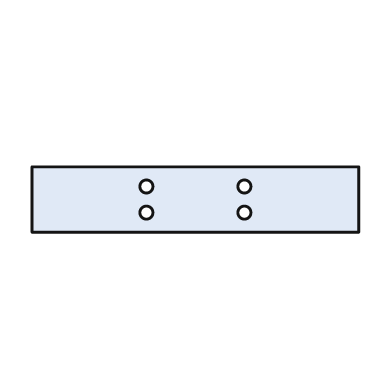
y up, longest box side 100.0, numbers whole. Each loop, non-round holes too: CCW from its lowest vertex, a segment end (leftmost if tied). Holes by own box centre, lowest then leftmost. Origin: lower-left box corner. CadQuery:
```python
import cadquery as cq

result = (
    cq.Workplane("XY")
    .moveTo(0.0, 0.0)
    .lineTo(100.0, 0.0)
    .lineTo(100.0, 20.0)
    .lineTo(0.0, 20.0)
    .close()
    .moveTo(35.0, 6.0)
    .circle(2.0)
    .moveTo(65.0, 6.0)
    .circle(2.0)
    .moveTo(35.0, 14.0)
    .circle(2.0)
    .moveTo(65.0, 14.0)
    .circle(2.0)
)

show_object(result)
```